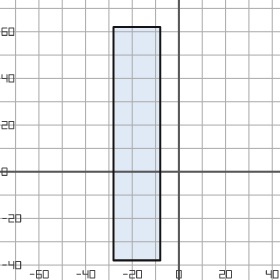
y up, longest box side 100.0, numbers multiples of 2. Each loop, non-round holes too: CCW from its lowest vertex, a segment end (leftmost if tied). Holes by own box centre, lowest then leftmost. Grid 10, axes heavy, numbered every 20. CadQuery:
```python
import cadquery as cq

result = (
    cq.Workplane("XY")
    .moveTo(-28.0, -38.0)
    .lineTo(-8.0, -38.0)
    .lineTo(-8.0, 62.0)
    .lineTo(-28.0, 62.0)
    .close()
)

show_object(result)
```